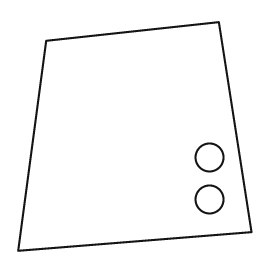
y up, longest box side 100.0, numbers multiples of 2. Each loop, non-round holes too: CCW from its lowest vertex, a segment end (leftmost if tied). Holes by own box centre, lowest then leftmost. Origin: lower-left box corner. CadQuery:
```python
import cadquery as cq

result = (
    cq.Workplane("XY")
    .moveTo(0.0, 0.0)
    .lineTo(100.0, 8.0)
    .lineTo(86.0, 98.0)
    .lineTo(12.0, 90.0)
    .close()
    .moveTo(82.0, 22.0)
    .circle(6.0)
    .moveTo(82.0, 40.0)
    .circle(6.0)
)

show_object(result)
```